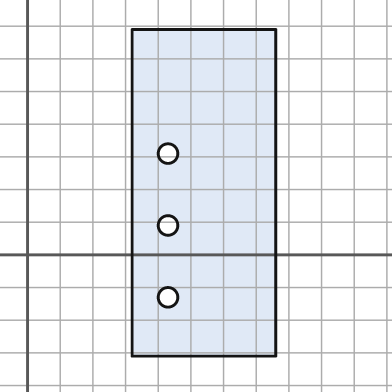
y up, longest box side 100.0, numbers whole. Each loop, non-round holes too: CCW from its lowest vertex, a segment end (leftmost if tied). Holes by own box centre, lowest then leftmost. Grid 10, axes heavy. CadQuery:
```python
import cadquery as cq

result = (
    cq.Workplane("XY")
    .moveTo(32.0, -31.0)
    .lineTo(76.0, -31.0)
    .lineTo(76.0, 69.0)
    .lineTo(32.0, 69.0)
    .close()
    .moveTo(43.0, -13.0)
    .circle(3.0)
    .moveTo(43.0, 9.0)
    .circle(3.0)
    .moveTo(43.0, 31.0)
    .circle(3.0)
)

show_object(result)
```